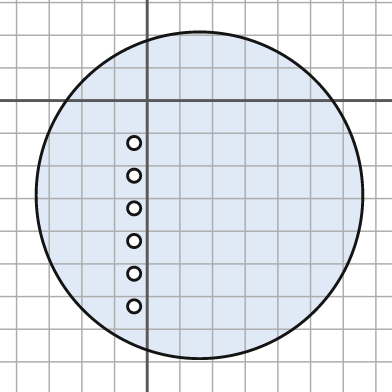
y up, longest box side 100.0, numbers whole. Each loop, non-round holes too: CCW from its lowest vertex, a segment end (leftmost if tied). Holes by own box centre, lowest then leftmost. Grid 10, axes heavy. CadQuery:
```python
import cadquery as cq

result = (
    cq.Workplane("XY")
    .moveTo(16.0, -29.0)
    .circle(50.0)
    .moveTo(-4.0, -63.0)
    .circle(2.0)
    .moveTo(-4.0, -53.0)
    .circle(2.0)
    .moveTo(-4.0, -43.0)
    .circle(2.0)
    .moveTo(-4.0, -33.0)
    .circle(2.0)
    .moveTo(-4.0, -23.0)
    .circle(2.0)
    .moveTo(-4.0, -13.0)
    .circle(2.0)
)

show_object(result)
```